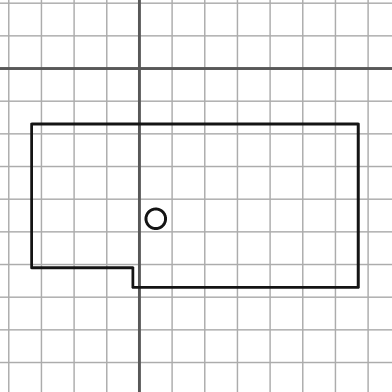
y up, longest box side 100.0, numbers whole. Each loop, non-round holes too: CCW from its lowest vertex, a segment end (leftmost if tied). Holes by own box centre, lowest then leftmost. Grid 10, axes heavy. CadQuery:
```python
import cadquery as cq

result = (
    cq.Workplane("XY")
    .moveTo(-2.0, -67.0)
    .lineTo(67.0, -67.0)
    .lineTo(67.0, -17.0)
    .lineTo(-33.0, -17.0)
    .lineTo(-33.0, -61.0)
    .lineTo(-2.0, -61.0)
    .close()
    .moveTo(5.0, -46.0)
    .circle(3.0)
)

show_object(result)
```